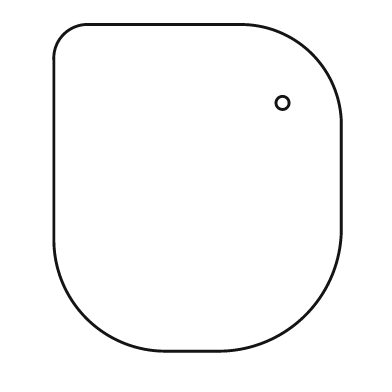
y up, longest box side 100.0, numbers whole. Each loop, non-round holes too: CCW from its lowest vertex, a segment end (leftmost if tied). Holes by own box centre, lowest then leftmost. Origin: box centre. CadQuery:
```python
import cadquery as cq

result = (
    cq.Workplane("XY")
    .moveTo(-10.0, -50.0)
    .lineTo(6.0, -50.0)
    .threePointArc((33.0, -39.0), (44.0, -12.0))
    .lineTo(44.0, 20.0)
    .threePointArc((35.0, 41.0), (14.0, 50.0))
    .lineTo(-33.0, 50.0)
    .threePointArc((-41.0, 47.0), (-44.0, 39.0))
    .lineTo(-44.0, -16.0)
    .threePointArc((-34.0, -40.0), (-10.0, -50.0))
    .close()
    .moveTo(26.0, 26.0)
    .circle(2.0)
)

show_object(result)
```